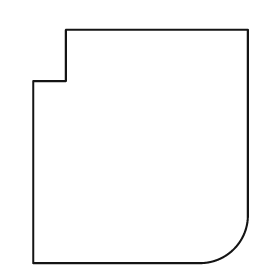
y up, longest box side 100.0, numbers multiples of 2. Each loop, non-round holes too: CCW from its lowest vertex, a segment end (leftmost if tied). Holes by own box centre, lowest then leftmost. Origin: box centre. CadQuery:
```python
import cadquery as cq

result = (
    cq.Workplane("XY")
    .moveTo(-46.0, -50.0)
    .lineTo(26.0, -50.0)
    .threePointArc((40.0, -44.0), (46.0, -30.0))
    .lineTo(46.0, 50.0)
    .lineTo(-32.0, 50.0)
    .lineTo(-32.0, 28.0)
    .lineTo(-46.0, 28.0)
    .close()
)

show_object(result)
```